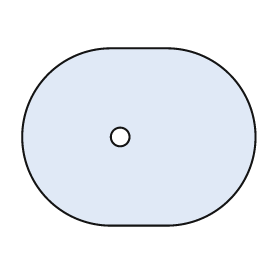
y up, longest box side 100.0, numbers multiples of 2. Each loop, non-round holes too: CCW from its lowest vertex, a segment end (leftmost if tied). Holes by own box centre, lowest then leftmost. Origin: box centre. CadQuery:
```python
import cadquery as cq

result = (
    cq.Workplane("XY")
    .moveTo(-12.0, -38.0)
    .lineTo(12.0, -38.0)
    .threePointArc((50.0, 0.0), (12.0, 38.0))
    .lineTo(-12.0, 38.0)
    .threePointArc((-50.0, 0.0), (-12.0, -38.0))
    .close()
    .moveTo(-8.0, 0.0)
    .circle(4.0)
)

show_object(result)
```